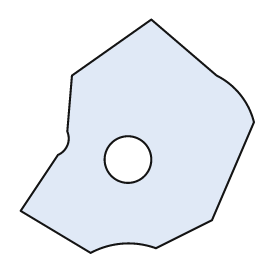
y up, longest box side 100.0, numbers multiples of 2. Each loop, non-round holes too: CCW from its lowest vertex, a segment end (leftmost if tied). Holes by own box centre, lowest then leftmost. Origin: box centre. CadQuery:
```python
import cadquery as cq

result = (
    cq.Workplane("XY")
    .moveTo(-20.0, -50.0)
    .threePointArc((-6.0, -46.0), (8.0, -48.0))
    .lineTo(32.0, -36.0)
    .lineTo(50.0, 6.0)
    .threePointArc((44.0, 18.0), (34.0, 26.0))
    .lineTo(6.0, 50.0)
    .lineTo(-28.0, 26.0)
    .lineTo(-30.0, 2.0)
    .threePointArc((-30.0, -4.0), (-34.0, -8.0))
    .lineTo(-50.0, -32.0)
    .close()
    .moveTo(-4.0, -10.0)
    .circle(10.0)
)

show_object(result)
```